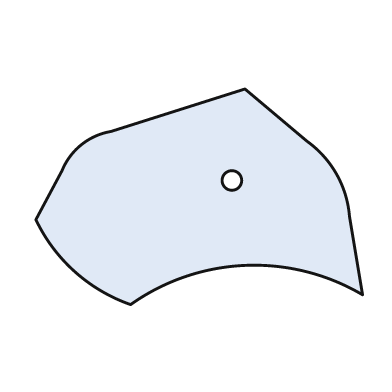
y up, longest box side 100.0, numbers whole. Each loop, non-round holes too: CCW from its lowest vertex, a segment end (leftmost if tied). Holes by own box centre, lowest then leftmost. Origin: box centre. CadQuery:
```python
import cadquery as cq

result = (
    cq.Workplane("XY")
    .moveTo(-21.0, -33.0)
    .threePointArc((14.0, -21.0), (50.0, -30.0))
    .lineTo(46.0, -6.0)
    .threePointArc((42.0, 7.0), (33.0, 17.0))
    .lineTo(14.0, 33.0)
    .lineTo(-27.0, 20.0)
    .threePointArc((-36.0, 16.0), (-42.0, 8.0))
    .lineTo(-50.0, -7.0)
    .threePointArc((-38.0, -23.0), (-21.0, -33.0))
    .close()
    .moveTo(10.0, 5.0)
    .circle(3.0)
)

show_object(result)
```